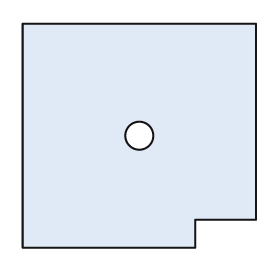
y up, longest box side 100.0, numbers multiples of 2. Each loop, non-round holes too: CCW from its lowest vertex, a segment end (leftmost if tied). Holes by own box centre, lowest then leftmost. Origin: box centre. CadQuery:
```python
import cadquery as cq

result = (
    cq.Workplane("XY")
    .moveTo(-50.0, -48.0)
    .lineTo(24.0, -48.0)
    .lineTo(24.0, -36.0)
    .lineTo(50.0, -36.0)
    .lineTo(50.0, 48.0)
    .lineTo(-50.0, 48.0)
    .close()
    .moveTo(0.0, 0.0)
    .circle(6.0)
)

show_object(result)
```